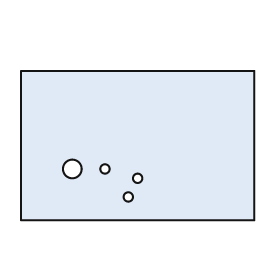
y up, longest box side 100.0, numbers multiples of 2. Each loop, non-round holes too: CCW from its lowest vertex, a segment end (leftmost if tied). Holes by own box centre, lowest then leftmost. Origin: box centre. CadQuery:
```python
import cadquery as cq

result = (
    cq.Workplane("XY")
    .moveTo(-50.0, -32.0)
    .lineTo(50.0, -32.0)
    .lineTo(50.0, 32.0)
    .lineTo(-50.0, 32.0)
    .close()
    .moveTo(-4.0, -22.0)
    .circle(2.0)
    .moveTo(0.0, -14.0)
    .circle(2.0)
    .moveTo(-28.0, -10.0)
    .circle(4.0)
    .moveTo(-14.0, -10.0)
    .circle(2.0)
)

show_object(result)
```